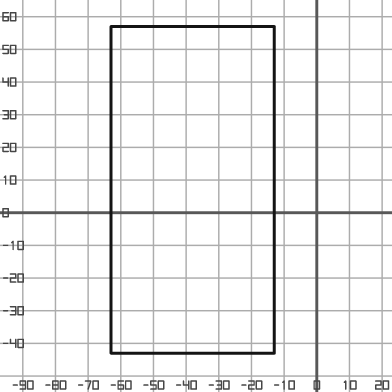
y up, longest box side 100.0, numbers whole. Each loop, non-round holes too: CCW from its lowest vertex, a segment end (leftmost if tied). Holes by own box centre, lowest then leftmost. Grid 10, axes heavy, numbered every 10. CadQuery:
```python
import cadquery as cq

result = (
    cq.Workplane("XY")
    .moveTo(-63.0, -43.0)
    .lineTo(-13.0, -43.0)
    .lineTo(-13.0, 57.0)
    .lineTo(-63.0, 57.0)
    .close()
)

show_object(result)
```